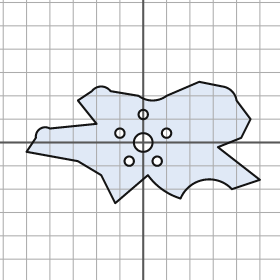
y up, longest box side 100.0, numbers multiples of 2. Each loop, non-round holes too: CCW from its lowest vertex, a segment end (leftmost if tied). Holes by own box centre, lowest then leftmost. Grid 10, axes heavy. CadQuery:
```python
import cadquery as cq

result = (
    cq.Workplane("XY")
    .moveTo(-12.0, -26.0)
    .lineTo(2.0, -14.0)
    .threePointArc((8.0, -20.0), (16.0, -24.0))
    .threePointArc((26.0, -16.0), (38.0, -20.0))
    .lineTo(50.0, -16.0)
    .lineTo(32.0, -2.0)
    .lineTo(42.0, 2.0)
    .lineTo(46.0, 10.0)
    .lineTo(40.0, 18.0)
    .threePointArc((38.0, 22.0), (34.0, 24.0))
    .lineTo(24.0, 26.0)
    .lineTo(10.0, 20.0)
    .threePointArc((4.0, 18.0), (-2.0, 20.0))
    .lineTo(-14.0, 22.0)
    .threePointArc((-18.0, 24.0), (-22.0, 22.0))
    .lineTo(-28.0, 18.0)
    .lineTo(-20.0, 8.0)
    .lineTo(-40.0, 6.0)
    .threePointArc((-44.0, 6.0), (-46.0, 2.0))
    .lineTo(-50.0, -4.0)
    .lineTo(-28.0, -8.0)
    .lineTo(-18.0, -14.0)
    .close()
    .moveTo(-6.0, -8.0)
    .circle(2.0)
    .moveTo(6.0, -8.0)
    .circle(2.0)
    .moveTo(0.0, 0.0)
    .circle(4.0)
    .moveTo(-10.0, 4.0)
    .circle(2.0)
    .moveTo(10.0, 4.0)
    .circle(2.0)
    .moveTo(0.0, 12.0)
    .circle(2.0)
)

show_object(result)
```